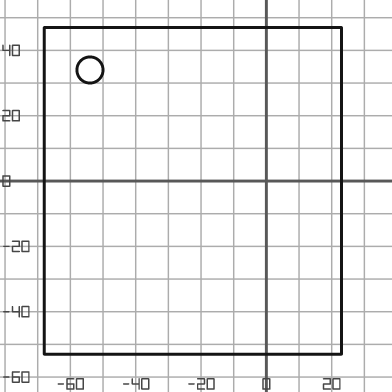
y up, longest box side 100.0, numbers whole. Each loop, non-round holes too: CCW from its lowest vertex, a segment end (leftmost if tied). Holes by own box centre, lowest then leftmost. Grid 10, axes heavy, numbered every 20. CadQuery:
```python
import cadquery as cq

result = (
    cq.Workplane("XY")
    .moveTo(-68.0, -53.0)
    .lineTo(23.0, -53.0)
    .lineTo(23.0, 47.0)
    .lineTo(-68.0, 47.0)
    .close()
    .moveTo(-54.0, 34.0)
    .circle(4.0)
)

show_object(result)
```